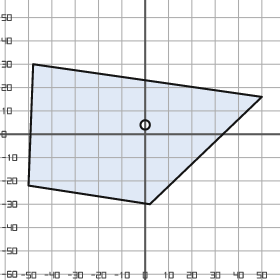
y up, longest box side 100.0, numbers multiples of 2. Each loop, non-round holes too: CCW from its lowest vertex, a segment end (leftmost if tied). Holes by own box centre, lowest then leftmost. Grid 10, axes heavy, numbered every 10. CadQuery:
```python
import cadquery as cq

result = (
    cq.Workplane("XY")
    .moveTo(2.0, -30.0)
    .lineTo(50.0, 16.0)
    .lineTo(-48.0, 30.0)
    .lineTo(-50.0, -22.0)
    .close()
    .moveTo(0.0, 4.0)
    .circle(2.0)
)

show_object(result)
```